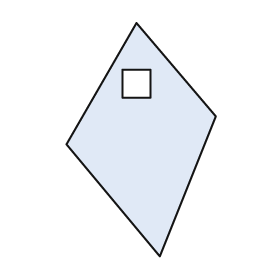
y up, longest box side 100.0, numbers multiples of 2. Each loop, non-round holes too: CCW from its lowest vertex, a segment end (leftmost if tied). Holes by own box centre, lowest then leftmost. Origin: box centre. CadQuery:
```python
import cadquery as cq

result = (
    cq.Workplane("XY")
    .moveTo(8.0, -50.0)
    .lineTo(32.0, 10.0)
    .lineTo(-2.0, 50.0)
    .lineTo(-32.0, -2.0)
    .close()
    .moveTo(-8.0, 18.0)
    .lineTo(4.0, 18.0)
    .lineTo(4.0, 30.0)
    .lineTo(-8.0, 30.0)
    .close()
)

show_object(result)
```